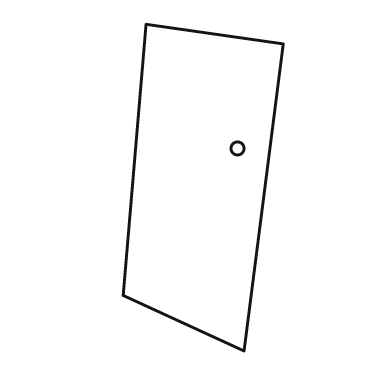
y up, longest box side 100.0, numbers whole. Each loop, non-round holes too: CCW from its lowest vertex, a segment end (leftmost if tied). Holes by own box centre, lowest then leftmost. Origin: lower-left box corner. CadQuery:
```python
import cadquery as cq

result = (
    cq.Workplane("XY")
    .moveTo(37.0, 0.0)
    .lineTo(49.0, 94.0)
    .lineTo(7.0, 100.0)
    .lineTo(0.0, 17.0)
    .close()
    .moveTo(35.0, 62.0)
    .circle(2.0)
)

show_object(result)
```